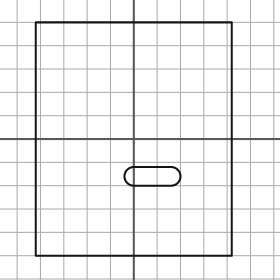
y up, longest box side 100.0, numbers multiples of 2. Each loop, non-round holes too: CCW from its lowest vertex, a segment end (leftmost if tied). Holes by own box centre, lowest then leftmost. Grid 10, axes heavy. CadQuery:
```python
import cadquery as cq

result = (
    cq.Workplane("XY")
    .moveTo(-42.0, -50.0)
    .lineTo(42.0, -50.0)
    .lineTo(42.0, 50.0)
    .lineTo(-42.0, 50.0)
    .close()
    .moveTo(0.0, -20.0)
    .lineTo(16.0, -20.0)
    .threePointArc((20.0, -16.0), (16.0, -12.0))
    .lineTo(0.0, -12.0)
    .threePointArc((-4.0, -16.0), (0.0, -20.0))
    .close()
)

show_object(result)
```